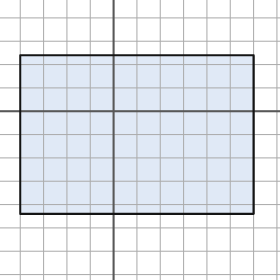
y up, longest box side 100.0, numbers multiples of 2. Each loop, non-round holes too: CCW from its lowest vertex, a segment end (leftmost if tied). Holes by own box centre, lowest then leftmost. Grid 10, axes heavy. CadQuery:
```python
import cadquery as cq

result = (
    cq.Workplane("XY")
    .moveTo(-40.0, -44.0)
    .lineTo(60.0, -44.0)
    .lineTo(60.0, 24.0)
    .lineTo(-40.0, 24.0)
    .close()
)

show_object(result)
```